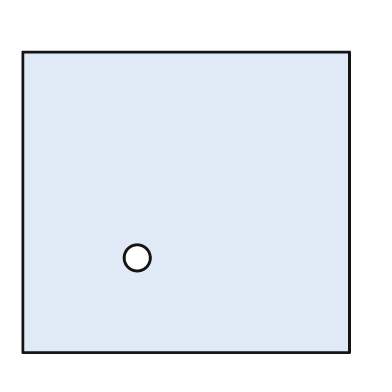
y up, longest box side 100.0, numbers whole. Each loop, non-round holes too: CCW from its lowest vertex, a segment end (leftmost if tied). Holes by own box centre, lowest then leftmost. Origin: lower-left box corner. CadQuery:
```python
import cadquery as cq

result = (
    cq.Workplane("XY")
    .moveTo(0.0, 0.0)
    .lineTo(100.0, 0.0)
    .lineTo(100.0, 92.0)
    .lineTo(0.0, 92.0)
    .close()
    .moveTo(35.0, 29.0)
    .circle(4.0)
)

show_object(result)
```